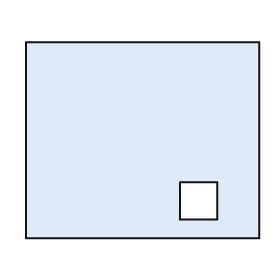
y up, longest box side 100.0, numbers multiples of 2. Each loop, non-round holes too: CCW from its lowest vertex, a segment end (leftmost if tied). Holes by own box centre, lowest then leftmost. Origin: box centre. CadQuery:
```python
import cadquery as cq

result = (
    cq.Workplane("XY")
    .moveTo(-50.0, -42.0)
    .lineTo(50.0, -42.0)
    .lineTo(50.0, 42.0)
    .lineTo(-50.0, 42.0)
    .close()
    .moveTo(16.0, -34.0)
    .lineTo(32.0, -34.0)
    .lineTo(32.0, -18.0)
    .lineTo(16.0, -18.0)
    .close()
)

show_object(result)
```